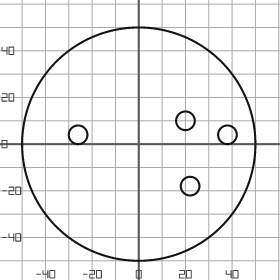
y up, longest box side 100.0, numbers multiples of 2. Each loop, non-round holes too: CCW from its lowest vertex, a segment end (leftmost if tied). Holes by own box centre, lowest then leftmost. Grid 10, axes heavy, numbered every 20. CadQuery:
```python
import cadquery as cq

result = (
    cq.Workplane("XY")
    .moveTo(0.0, 0.0)
    .circle(50.0)
    .moveTo(22.0, -18.0)
    .circle(4.0)
    .moveTo(-26.0, 4.0)
    .circle(4.0)
    .moveTo(38.0, 4.0)
    .circle(4.0)
    .moveTo(20.0, 10.0)
    .circle(4.0)
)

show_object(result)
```